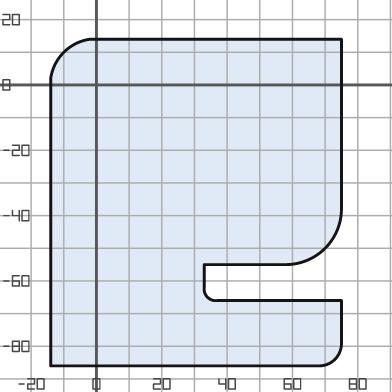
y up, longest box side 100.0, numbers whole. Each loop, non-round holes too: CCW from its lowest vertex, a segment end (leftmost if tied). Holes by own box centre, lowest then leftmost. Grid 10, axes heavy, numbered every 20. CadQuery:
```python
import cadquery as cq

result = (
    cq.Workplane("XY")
    .moveTo(-14.0, -86.0)
    .lineTo(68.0, -86.0)
    .threePointArc((73.0, -84.0), (75.0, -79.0))
    .lineTo(75.0, -66.0)
    .lineTo(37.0, -66.0)
    .threePointArc((34.0, -65.0), (33.0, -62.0))
    .lineTo(33.0, -55.0)
    .lineTo(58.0, -55.0)
    .threePointArc((70.0, -50.0), (75.0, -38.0))
    .lineTo(75.0, 14.0)
    .lineTo(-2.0, 14.0)
    .threePointArc((-10.0, 10.0), (-14.0, 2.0))
    .close()
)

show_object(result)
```